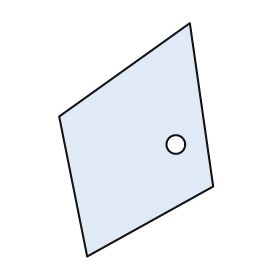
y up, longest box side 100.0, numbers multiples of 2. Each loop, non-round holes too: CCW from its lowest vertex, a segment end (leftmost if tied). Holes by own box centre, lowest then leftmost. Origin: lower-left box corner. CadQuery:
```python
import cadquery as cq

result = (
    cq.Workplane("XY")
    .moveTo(12.0, 0.0)
    .lineTo(66.0, 30.0)
    .lineTo(56.0, 100.0)
    .lineTo(0.0, 60.0)
    .close()
    .moveTo(50.0, 48.0)
    .circle(4.0)
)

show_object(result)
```